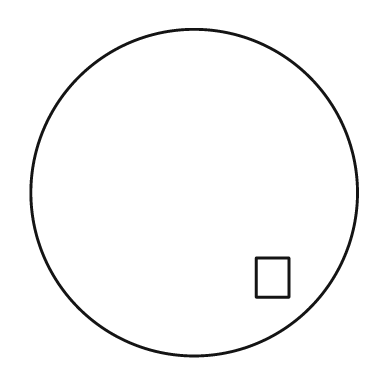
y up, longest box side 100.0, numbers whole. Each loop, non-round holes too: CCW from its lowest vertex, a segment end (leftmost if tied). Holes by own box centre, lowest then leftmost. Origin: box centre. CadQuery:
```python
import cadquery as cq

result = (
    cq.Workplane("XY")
    .moveTo(0.0, 0.0)
    .circle(50.0)
    .moveTo(19.0, -32.0)
    .lineTo(29.0, -32.0)
    .lineTo(29.0, -20.0)
    .lineTo(19.0, -20.0)
    .close()
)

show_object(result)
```